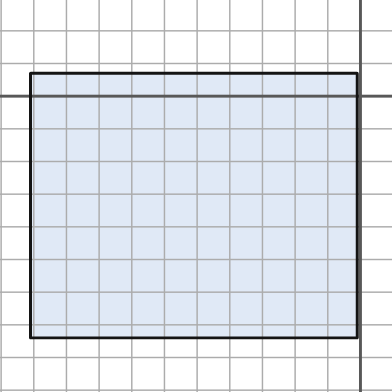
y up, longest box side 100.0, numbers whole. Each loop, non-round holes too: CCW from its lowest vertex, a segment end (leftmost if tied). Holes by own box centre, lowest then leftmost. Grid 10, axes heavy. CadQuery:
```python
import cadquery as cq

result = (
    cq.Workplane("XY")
    .moveTo(-101.0, -74.0)
    .lineTo(-1.0, -74.0)
    .lineTo(-1.0, 7.0)
    .lineTo(-101.0, 7.0)
    .close()
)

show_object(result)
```